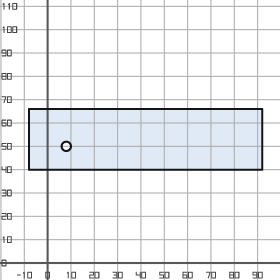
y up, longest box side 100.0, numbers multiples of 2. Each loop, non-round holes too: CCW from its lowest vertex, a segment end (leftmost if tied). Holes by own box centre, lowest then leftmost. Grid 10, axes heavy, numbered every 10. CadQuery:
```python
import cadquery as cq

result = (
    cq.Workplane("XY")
    .moveTo(-8.0, 40.0)
    .lineTo(92.0, 40.0)
    .lineTo(92.0, 66.0)
    .lineTo(-8.0, 66.0)
    .close()
    .moveTo(8.0, 50.0)
    .circle(2.0)
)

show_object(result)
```